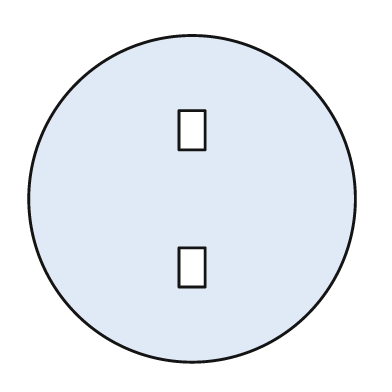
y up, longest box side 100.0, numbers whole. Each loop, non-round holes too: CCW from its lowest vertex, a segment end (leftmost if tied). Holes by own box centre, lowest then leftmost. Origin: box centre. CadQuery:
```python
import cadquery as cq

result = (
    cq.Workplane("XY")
    .moveTo(0.0, 0.0)
    .circle(50.0)
    .moveTo(-4.0, -27.0)
    .lineTo(4.0, -27.0)
    .lineTo(4.0, -15.0)
    .lineTo(-4.0, -15.0)
    .close()
    .moveTo(-4.0, 15.0)
    .lineTo(4.0, 15.0)
    .lineTo(4.0, 27.0)
    .lineTo(-4.0, 27.0)
    .close()
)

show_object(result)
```